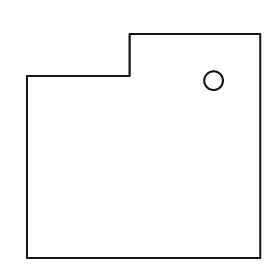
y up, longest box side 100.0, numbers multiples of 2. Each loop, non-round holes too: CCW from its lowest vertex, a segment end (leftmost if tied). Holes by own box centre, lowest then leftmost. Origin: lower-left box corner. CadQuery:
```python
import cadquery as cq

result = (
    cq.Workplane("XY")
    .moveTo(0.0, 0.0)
    .lineTo(100.0, 0.0)
    .lineTo(100.0, 96.0)
    .lineTo(44.0, 96.0)
    .lineTo(44.0, 78.0)
    .lineTo(0.0, 78.0)
    .close()
    .moveTo(80.0, 76.0)
    .circle(4.0)
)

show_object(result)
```